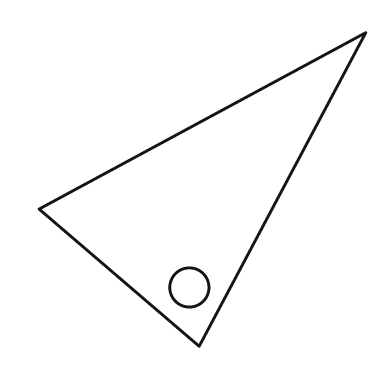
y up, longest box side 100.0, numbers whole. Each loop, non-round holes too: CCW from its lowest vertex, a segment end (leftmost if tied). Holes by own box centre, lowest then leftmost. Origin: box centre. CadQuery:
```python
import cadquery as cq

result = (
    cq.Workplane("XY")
    .moveTo(-1.0, -48.0)
    .lineTo(50.0, 48.0)
    .lineTo(-50.0, -6.0)
    .close()
    .moveTo(-4.0, -30.0)
    .circle(6.0)
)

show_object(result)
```